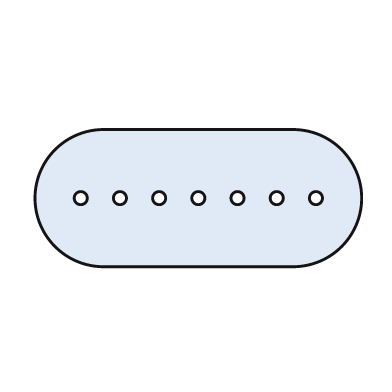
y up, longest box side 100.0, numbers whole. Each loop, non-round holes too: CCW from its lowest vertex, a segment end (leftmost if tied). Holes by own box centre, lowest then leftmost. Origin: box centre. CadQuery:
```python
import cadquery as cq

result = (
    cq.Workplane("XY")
    .moveTo(-29.0, -21.0)
    .lineTo(29.0, -21.0)
    .threePointArc((50.0, 0.0), (29.0, 21.0))
    .lineTo(-29.0, 21.0)
    .threePointArc((-50.0, 0.0), (-29.0, -21.0))
    .close()
    .moveTo(-36.0, 0.0)
    .circle(2.0)
    .moveTo(-24.0, 0.0)
    .circle(2.0)
    .moveTo(-12.0, 0.0)
    .circle(2.0)
    .moveTo(0.0, 0.0)
    .circle(2.0)
    .moveTo(12.0, 0.0)
    .circle(2.0)
    .moveTo(24.0, 0.0)
    .circle(2.0)
    .moveTo(36.0, 0.0)
    .circle(2.0)
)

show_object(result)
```